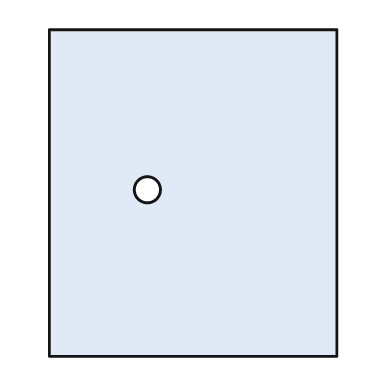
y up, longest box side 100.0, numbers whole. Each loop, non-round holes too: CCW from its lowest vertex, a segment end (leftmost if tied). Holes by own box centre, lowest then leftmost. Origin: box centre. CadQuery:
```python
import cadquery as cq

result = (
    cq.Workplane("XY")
    .moveTo(-44.0, -50.0)
    .lineTo(44.0, -50.0)
    .lineTo(44.0, 50.0)
    .lineTo(-44.0, 50.0)
    .close()
    .moveTo(-14.0, 1.0)
    .circle(4.0)
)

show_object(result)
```